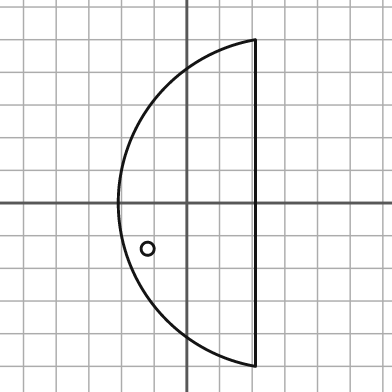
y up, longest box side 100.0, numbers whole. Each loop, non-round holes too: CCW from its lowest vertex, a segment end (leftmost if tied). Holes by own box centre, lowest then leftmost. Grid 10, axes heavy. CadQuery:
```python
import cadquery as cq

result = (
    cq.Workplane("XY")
    .moveTo(21.0, -50.0)
    .lineTo(21.0, 50.0)
    .threePointArc((-21.0, 0.0), (21.0, -50.0))
    .close()
    .moveTo(-12.0, -14.0)
    .circle(2.0)
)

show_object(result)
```